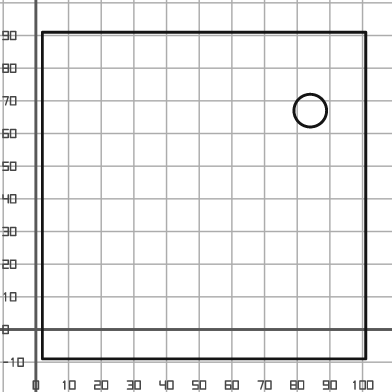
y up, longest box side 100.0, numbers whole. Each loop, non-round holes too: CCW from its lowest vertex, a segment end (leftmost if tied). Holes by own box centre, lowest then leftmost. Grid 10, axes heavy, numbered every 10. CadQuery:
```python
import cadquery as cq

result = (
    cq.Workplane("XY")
    .moveTo(2.0, -9.0)
    .lineTo(101.0, -9.0)
    .lineTo(101.0, 91.0)
    .lineTo(2.0, 91.0)
    .close()
    .moveTo(84.0, 67.0)
    .circle(5.0)
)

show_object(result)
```